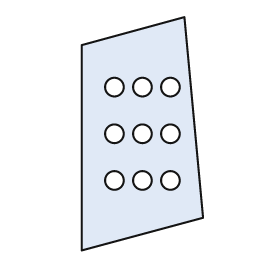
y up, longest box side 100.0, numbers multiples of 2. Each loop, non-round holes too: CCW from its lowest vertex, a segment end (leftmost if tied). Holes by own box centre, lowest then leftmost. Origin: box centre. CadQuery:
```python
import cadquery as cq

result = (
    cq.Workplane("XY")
    .moveTo(-26.0, -50.0)
    .lineTo(26.0, -36.0)
    .lineTo(18.0, 50.0)
    .lineTo(-26.0, 38.0)
    .close()
    .moveTo(-12.0, -20.0)
    .circle(4.0)
    .moveTo(0.0, -20.0)
    .circle(4.0)
    .moveTo(12.0, -20.0)
    .circle(4.0)
    .moveTo(-12.0, 0.0)
    .circle(4.0)
    .moveTo(0.0, 0.0)
    .circle(4.0)
    .moveTo(12.0, 0.0)
    .circle(4.0)
    .moveTo(-12.0, 20.0)
    .circle(4.0)
    .moveTo(0.0, 20.0)
    .circle(4.0)
    .moveTo(12.0, 20.0)
    .circle(4.0)
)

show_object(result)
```